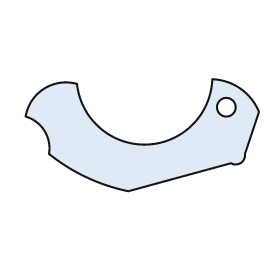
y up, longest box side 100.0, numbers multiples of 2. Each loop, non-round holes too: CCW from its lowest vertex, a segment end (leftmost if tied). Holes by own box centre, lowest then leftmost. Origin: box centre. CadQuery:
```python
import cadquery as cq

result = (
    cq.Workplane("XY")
    .moveTo(-6.0, -24.0)
    .lineTo(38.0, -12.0)
    .threePointArc((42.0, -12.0), (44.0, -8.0))
    .lineTo(50.0, 10.0)
    .threePointArc((42.0, 20.0), (30.0, 24.0))
    .threePointArc((2.0, -4.0), (-28.0, 22.0))
    .threePointArc((-42.0, 20.0), (-50.0, 8.0))
    .threePointArc((-42.0, 2.0), (-40.0, -8.0))
    .threePointArc((-24.0, -18.0), (-6.0, -24.0))
    .close()
    .moveTo(36.0, 12.0)
    .circle(4.0)
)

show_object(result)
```